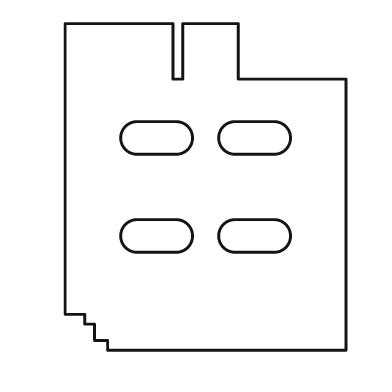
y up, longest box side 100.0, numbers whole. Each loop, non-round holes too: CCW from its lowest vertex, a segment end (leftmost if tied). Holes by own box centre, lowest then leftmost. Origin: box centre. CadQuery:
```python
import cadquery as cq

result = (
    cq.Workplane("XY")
    .moveTo(-30.0, -50.0)
    .lineTo(43.0, -50.0)
    .lineTo(43.0, 33.0)
    .lineTo(10.0, 33.0)
    .lineTo(10.0, 50.0)
    .lineTo(-7.0, 50.0)
    .lineTo(-7.0, 33.0)
    .lineTo(-10.0, 33.0)
    .lineTo(-10.0, 50.0)
    .lineTo(-43.0, 50.0)
    .lineTo(-43.0, -39.0)
    .lineTo(-37.0, -39.0)
    .lineTo(-37.0, -42.0)
    .lineTo(-34.0, -42.0)
    .lineTo(-34.0, -47.0)
    .lineTo(-30.0, -47.0)
    .close()
    .moveTo(-21.0, -20.0)
    .lineTo(-9.0, -20.0)
    .threePointArc((-4.0, -15.0), (-9.0, -10.0))
    .lineTo(-21.0, -10.0)
    .threePointArc((-26.0, -15.0), (-21.0, -20.0))
    .close()
    .moveTo(9.0, -20.0)
    .lineTo(21.0, -20.0)
    .threePointArc((26.0, -15.0), (21.0, -10.0))
    .lineTo(9.0, -10.0)
    .threePointArc((4.0, -15.0), (9.0, -20.0))
    .close()
    .moveTo(-21.0, 10.0)
    .lineTo(-9.0, 10.0)
    .threePointArc((-4.0, 15.0), (-9.0, 20.0))
    .lineTo(-21.0, 20.0)
    .threePointArc((-26.0, 15.0), (-21.0, 10.0))
    .close()
    .moveTo(9.0, 10.0)
    .lineTo(21.0, 10.0)
    .threePointArc((26.0, 15.0), (21.0, 20.0))
    .lineTo(9.0, 20.0)
    .threePointArc((4.0, 15.0), (9.0, 10.0))
    .close()
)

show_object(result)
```